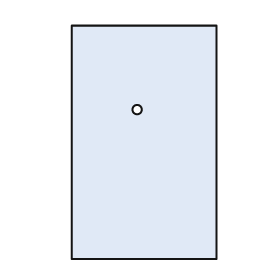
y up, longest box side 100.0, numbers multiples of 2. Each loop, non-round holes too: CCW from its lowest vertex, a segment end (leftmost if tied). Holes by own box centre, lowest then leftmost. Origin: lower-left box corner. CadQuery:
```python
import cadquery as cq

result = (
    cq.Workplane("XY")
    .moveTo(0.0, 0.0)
    .lineTo(62.0, 0.0)
    .lineTo(62.0, 100.0)
    .lineTo(0.0, 100.0)
    .close()
    .moveTo(28.0, 64.0)
    .circle(2.0)
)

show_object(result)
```